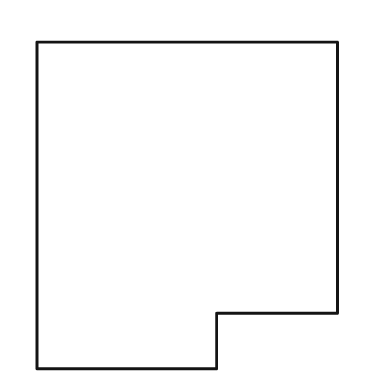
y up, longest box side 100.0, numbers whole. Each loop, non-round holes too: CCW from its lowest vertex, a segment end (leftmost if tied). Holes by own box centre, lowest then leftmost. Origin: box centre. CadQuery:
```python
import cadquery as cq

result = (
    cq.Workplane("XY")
    .moveTo(-46.0, -50.0)
    .lineTo(9.0, -50.0)
    .lineTo(9.0, -33.0)
    .lineTo(46.0, -33.0)
    .lineTo(46.0, 50.0)
    .lineTo(-46.0, 50.0)
    .close()
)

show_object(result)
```